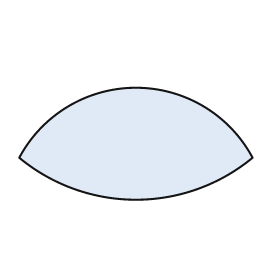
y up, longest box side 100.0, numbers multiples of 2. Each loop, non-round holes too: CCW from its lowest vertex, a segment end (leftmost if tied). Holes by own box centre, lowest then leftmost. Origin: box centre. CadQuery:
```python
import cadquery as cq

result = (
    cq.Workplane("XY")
    .moveTo(-50.0, -6.0)
    .threePointArc((0.0, -24.0), (50.0, -6.0))
    .threePointArc((0.0, 24.0), (-50.0, -6.0))
    .close()
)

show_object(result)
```